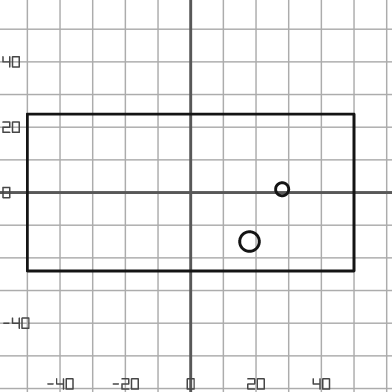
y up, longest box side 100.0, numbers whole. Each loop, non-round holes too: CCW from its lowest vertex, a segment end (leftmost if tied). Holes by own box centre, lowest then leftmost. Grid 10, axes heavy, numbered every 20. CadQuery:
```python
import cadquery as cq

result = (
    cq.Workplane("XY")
    .moveTo(-50.0, -24.0)
    .lineTo(50.0, -24.0)
    .lineTo(50.0, 24.0)
    .lineTo(-50.0, 24.0)
    .close()
    .moveTo(18.0, -15.0)
    .circle(3.0)
    .moveTo(28.0, 1.0)
    .circle(2.0)
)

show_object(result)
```